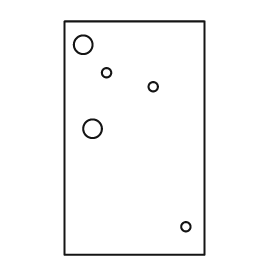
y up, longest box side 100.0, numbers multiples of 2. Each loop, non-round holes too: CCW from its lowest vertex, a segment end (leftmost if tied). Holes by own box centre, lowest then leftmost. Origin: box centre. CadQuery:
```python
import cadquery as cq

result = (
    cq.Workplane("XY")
    .moveTo(-30.0, -50.0)
    .lineTo(30.0, -50.0)
    .lineTo(30.0, 50.0)
    .lineTo(-30.0, 50.0)
    .close()
    .moveTo(22.0, -38.0)
    .circle(2.0)
    .moveTo(-18.0, 4.0)
    .circle(4.0)
    .moveTo(8.0, 22.0)
    .circle(2.0)
    .moveTo(-12.0, 28.0)
    .circle(2.0)
    .moveTo(-22.0, 40.0)
    .circle(4.0)
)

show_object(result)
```